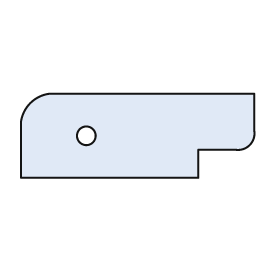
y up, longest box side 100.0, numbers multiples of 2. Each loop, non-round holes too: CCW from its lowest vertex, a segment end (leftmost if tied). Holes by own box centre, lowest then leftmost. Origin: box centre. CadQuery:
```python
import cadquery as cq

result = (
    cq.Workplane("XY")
    .moveTo(-50.0, -18.0)
    .lineTo(26.0, -18.0)
    .lineTo(26.0, -6.0)
    .lineTo(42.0, -6.0)
    .threePointArc((48.0, -4.0), (50.0, 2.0))
    .lineTo(50.0, 18.0)
    .lineTo(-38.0, 18.0)
    .threePointArc((-46.0, 14.0), (-50.0, 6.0))
    .close()
    .moveTo(-22.0, 0.0)
    .circle(4.0)
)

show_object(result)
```